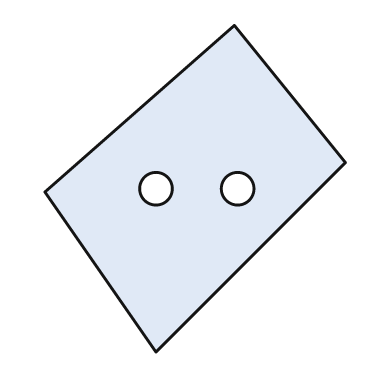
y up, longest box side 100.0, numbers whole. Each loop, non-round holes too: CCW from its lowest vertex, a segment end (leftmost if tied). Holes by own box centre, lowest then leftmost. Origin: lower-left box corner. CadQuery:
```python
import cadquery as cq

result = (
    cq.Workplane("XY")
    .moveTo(34.0, 0.0)
    .lineTo(92.0, 58.0)
    .lineTo(58.0, 100.0)
    .lineTo(0.0, 49.0)
    .close()
    .moveTo(34.0, 50.0)
    .circle(5.0)
    .moveTo(59.0, 50.0)
    .circle(5.0)
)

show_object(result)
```